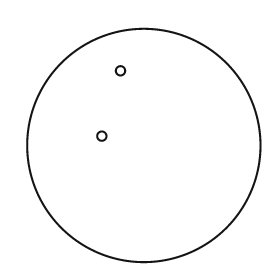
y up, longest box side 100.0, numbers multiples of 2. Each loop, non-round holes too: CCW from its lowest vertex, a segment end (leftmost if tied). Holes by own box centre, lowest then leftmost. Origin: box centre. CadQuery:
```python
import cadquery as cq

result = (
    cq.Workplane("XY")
    .moveTo(0.0, 0.0)
    .circle(50.0)
    .moveTo(-18.0, 4.0)
    .circle(2.0)
    .moveTo(-10.0, 32.0)
    .circle(2.0)
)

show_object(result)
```